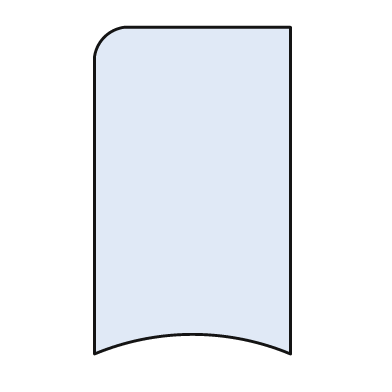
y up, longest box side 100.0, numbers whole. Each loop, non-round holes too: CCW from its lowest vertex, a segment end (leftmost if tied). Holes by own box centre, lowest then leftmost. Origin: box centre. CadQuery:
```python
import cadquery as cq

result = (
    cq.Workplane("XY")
    .moveTo(-30.0, -50.0)
    .threePointArc((0.0, -44.0), (30.0, -50.0))
    .lineTo(30.0, 50.0)
    .lineTo(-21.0, 50.0)
    .threePointArc((-27.0, 47.0), (-30.0, 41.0))
    .close()
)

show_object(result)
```